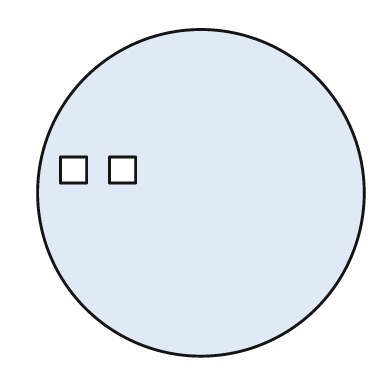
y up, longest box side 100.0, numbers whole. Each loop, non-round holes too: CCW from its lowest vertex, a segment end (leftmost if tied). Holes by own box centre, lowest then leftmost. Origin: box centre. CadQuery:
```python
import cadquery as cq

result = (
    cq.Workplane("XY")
    .moveTo(0.0, 0.0)
    .circle(50.0)
    .moveTo(-43.0, 3.0)
    .lineTo(-35.0, 3.0)
    .lineTo(-35.0, 11.0)
    .lineTo(-43.0, 11.0)
    .close()
    .moveTo(-28.0, 3.0)
    .lineTo(-20.0, 3.0)
    .lineTo(-20.0, 11.0)
    .lineTo(-28.0, 11.0)
    .close()
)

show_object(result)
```